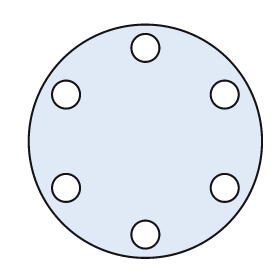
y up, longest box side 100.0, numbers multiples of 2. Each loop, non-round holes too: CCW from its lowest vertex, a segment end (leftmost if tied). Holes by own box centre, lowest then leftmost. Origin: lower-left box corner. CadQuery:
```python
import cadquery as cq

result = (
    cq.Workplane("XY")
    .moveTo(50.0, 50.0)
    .circle(50.0)
    .moveTo(50.0, 10.0)
    .circle(6.0)
    .moveTo(16.0, 30.0)
    .circle(6.0)
    .moveTo(84.0, 30.0)
    .circle(6.0)
    .moveTo(16.0, 70.0)
    .circle(6.0)
    .moveTo(84.0, 70.0)
    .circle(6.0)
    .moveTo(50.0, 90.0)
    .circle(6.0)
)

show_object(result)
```